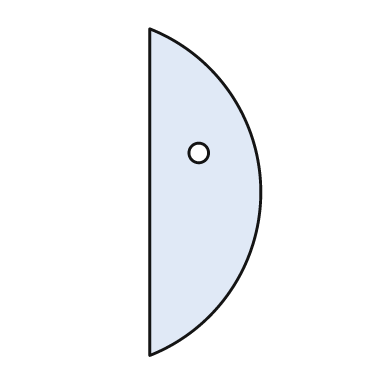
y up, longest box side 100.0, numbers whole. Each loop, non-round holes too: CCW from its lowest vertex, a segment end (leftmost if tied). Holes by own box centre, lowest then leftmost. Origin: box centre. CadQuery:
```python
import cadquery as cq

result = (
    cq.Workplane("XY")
    .moveTo(-17.0, -50.0)
    .threePointArc((17.0, 0.0), (-17.0, 50.0))
    .close()
    .moveTo(-2.0, 12.0)
    .circle(3.0)
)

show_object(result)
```